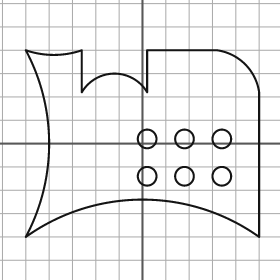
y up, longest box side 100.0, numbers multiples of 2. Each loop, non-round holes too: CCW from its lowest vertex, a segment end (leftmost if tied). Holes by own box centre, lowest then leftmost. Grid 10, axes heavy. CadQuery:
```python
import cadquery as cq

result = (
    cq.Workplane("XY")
    .moveTo(-50.0, -40.0)
    .threePointArc((0.0, -24.0), (50.0, -40.0))
    .lineTo(50.0, 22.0)
    .threePointArc((44.0, 34.0), (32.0, 40.0))
    .lineTo(2.0, 40.0)
    .lineTo(2.0, 22.0)
    .threePointArc((-12.0, 30.0), (-26.0, 22.0))
    .lineTo(-26.0, 40.0)
    .threePointArc((-38.0, 38.0), (-50.0, 40.0))
    .threePointArc((-40.0, 0.0), (-50.0, -40.0))
    .close()
    .moveTo(2.0, -14.0)
    .circle(4.0)
    .moveTo(18.0, -14.0)
    .circle(4.0)
    .moveTo(34.0, -14.0)
    .circle(4.0)
    .moveTo(2.0, 2.0)
    .circle(4.0)
    .moveTo(18.0, 2.0)
    .circle(4.0)
    .moveTo(34.0, 2.0)
    .circle(4.0)
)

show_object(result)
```